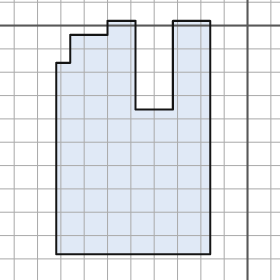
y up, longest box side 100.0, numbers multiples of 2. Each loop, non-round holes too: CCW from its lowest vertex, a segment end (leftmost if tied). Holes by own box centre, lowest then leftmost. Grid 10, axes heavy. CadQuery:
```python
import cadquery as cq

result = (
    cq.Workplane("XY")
    .moveTo(-82.0, -98.0)
    .lineTo(-16.0, -98.0)
    .lineTo(-16.0, 2.0)
    .lineTo(-32.0, 2.0)
    .lineTo(-32.0, -36.0)
    .lineTo(-48.0, -36.0)
    .lineTo(-48.0, 2.0)
    .lineTo(-60.0, 2.0)
    .lineTo(-60.0, -4.0)
    .lineTo(-76.0, -4.0)
    .lineTo(-76.0, -16.0)
    .lineTo(-82.0, -16.0)
    .close()
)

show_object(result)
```